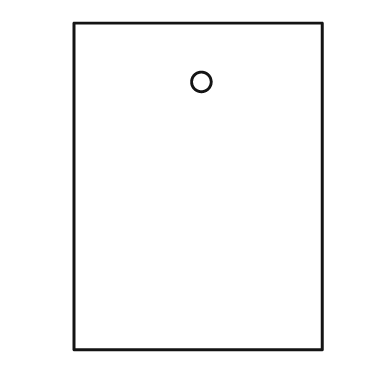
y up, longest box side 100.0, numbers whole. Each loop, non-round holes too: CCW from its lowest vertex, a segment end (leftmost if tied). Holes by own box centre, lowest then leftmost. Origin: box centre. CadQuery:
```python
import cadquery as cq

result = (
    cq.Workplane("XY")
    .moveTo(-38.0, -50.0)
    .lineTo(38.0, -50.0)
    .lineTo(38.0, 50.0)
    .lineTo(-38.0, 50.0)
    .close()
    .moveTo(1.0, 32.0)
    .circle(3.0)
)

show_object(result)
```